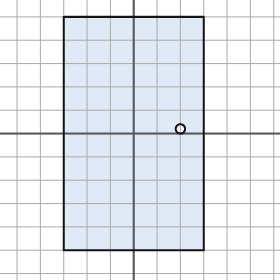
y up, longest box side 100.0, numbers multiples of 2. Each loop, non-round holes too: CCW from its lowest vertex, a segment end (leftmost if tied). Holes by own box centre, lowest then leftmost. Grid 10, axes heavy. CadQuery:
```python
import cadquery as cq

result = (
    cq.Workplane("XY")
    .moveTo(-30.0, -50.0)
    .lineTo(30.0, -50.0)
    .lineTo(30.0, 50.0)
    .lineTo(-30.0, 50.0)
    .close()
    .moveTo(20.0, 2.0)
    .circle(2.0)
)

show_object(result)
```